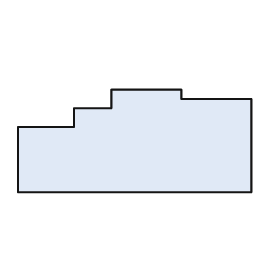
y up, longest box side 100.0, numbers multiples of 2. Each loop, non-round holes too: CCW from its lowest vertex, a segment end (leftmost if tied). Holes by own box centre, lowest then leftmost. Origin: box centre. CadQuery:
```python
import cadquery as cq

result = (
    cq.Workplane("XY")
    .moveTo(-50.0, -22.0)
    .lineTo(50.0, -22.0)
    .lineTo(50.0, 18.0)
    .lineTo(20.0, 18.0)
    .lineTo(20.0, 22.0)
    .lineTo(-10.0, 22.0)
    .lineTo(-10.0, 14.0)
    .lineTo(-26.0, 14.0)
    .lineTo(-26.0, 6.0)
    .lineTo(-50.0, 6.0)
    .close()
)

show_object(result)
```